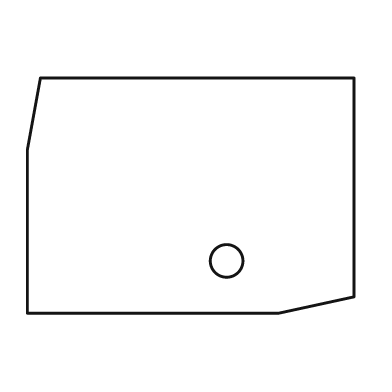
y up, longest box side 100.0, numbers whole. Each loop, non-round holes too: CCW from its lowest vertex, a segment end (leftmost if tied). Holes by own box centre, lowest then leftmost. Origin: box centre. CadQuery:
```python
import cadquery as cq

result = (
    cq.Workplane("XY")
    .moveTo(-50.0, -36.0)
    .lineTo(27.0, -36.0)
    .lineTo(50.0, -31.0)
    .lineTo(50.0, 36.0)
    .lineTo(-46.0, 36.0)
    .lineTo(-50.0, 14.0)
    .close()
    .moveTo(11.0, -20.0)
    .circle(5.0)
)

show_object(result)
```